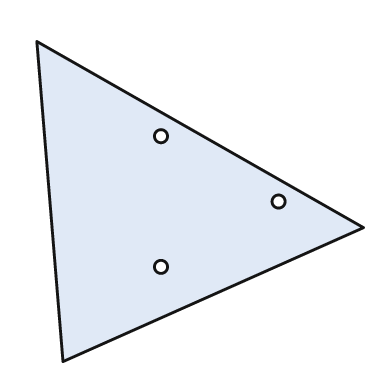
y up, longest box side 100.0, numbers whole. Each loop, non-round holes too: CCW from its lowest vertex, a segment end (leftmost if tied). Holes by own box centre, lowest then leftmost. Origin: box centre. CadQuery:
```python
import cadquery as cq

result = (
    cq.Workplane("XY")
    .moveTo(-42.0, -49.0)
    .lineTo(50.0, -8.0)
    .lineTo(-50.0, 49.0)
    .close()
    .moveTo(-12.0, -20.0)
    .circle(2.0)
    .moveTo(24.0, 0.0)
    .circle(2.0)
    .moveTo(-12.0, 20.0)
    .circle(2.0)
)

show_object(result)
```